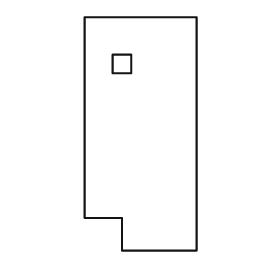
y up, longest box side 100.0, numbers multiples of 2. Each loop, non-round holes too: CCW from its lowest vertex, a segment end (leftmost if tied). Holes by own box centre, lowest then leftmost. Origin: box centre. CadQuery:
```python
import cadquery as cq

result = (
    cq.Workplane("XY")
    .moveTo(-8.0, -50.0)
    .lineTo(24.0, -50.0)
    .lineTo(24.0, 50.0)
    .lineTo(-24.0, 50.0)
    .lineTo(-24.0, -36.0)
    .lineTo(-8.0, -36.0)
    .close()
    .moveTo(-12.0, 26.0)
    .lineTo(-4.0, 26.0)
    .lineTo(-4.0, 34.0)
    .lineTo(-12.0, 34.0)
    .close()
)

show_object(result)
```